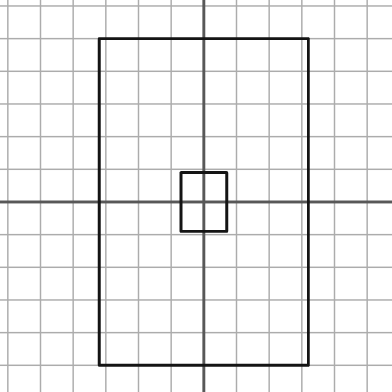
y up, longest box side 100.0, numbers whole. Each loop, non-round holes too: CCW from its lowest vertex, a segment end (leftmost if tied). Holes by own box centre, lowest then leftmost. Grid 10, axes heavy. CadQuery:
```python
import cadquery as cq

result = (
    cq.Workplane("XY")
    .moveTo(-32.0, -50.0)
    .lineTo(32.0, -50.0)
    .lineTo(32.0, 50.0)
    .lineTo(-32.0, 50.0)
    .close()
    .moveTo(-7.0, -9.0)
    .lineTo(7.0, -9.0)
    .lineTo(7.0, 9.0)
    .lineTo(-7.0, 9.0)
    .close()
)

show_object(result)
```